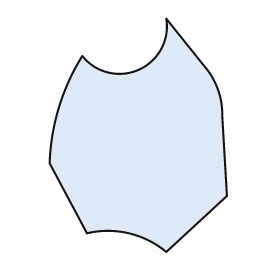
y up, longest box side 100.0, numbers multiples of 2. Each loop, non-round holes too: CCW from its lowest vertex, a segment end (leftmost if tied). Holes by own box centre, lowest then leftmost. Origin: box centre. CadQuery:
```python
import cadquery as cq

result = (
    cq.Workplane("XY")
    .moveTo(12.0, -50.0)
    .lineTo(38.0, -26.0)
    .lineTo(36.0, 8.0)
    .threePointArc((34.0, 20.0), (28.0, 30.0))
    .lineTo(12.0, 50.0)
    .threePointArc((0.0, 28.0), (-24.0, 34.0))
    .threePointArc((-34.0, 12.0), (-38.0, -12.0))
    .lineTo(-22.0, -42.0)
    .threePointArc((-4.0, -42.0), (12.0, -50.0))
    .close()
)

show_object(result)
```